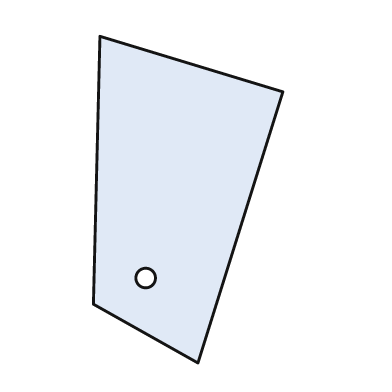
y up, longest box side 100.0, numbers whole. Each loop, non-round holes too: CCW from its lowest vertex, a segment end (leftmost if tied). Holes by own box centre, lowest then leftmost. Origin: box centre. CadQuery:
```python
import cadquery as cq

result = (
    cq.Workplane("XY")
    .moveTo(3.0, -50.0)
    .lineTo(29.0, 33.0)
    .lineTo(-27.0, 50.0)
    .lineTo(-29.0, -32.0)
    .close()
    .moveTo(-13.0, -24.0)
    .circle(3.0)
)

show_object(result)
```